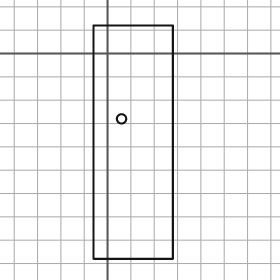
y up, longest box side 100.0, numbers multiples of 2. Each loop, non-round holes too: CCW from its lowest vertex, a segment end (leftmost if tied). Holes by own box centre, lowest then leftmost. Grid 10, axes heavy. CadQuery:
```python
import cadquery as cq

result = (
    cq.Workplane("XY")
    .moveTo(-6.0, -88.0)
    .lineTo(28.0, -88.0)
    .lineTo(28.0, 12.0)
    .lineTo(-6.0, 12.0)
    .close()
    .moveTo(6.0, -28.0)
    .circle(2.0)
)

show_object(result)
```